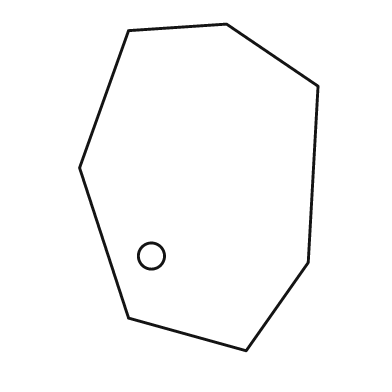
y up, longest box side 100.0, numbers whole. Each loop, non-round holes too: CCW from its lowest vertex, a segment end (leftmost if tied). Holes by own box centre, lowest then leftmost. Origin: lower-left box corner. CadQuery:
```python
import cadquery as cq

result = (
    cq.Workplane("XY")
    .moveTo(51.0, 0.0)
    .lineTo(70.0, 27.0)
    .lineTo(73.0, 81.0)
    .lineTo(45.0, 100.0)
    .lineTo(15.0, 98.0)
    .lineTo(0.0, 56.0)
    .lineTo(15.0, 10.0)
    .close()
    .moveTo(22.0, 29.0)
    .circle(4.0)
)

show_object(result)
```